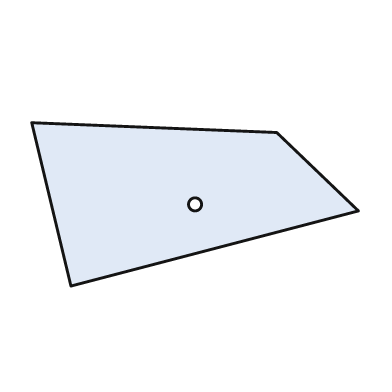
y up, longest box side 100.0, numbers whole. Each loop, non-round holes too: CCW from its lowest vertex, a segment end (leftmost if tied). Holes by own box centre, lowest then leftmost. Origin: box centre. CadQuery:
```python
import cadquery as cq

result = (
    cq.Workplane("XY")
    .moveTo(-38.0, -25.0)
    .lineTo(50.0, -2.0)
    .lineTo(25.0, 22.0)
    .lineTo(-50.0, 25.0)
    .close()
    .moveTo(0.0, 0.0)
    .circle(2.0)
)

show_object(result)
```